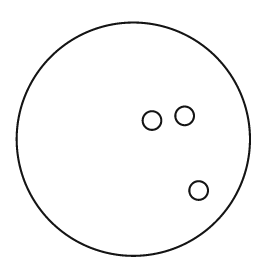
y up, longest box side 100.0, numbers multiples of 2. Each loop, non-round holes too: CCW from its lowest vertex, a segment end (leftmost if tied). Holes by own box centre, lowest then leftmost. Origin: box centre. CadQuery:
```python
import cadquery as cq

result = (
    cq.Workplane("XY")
    .moveTo(0.0, 0.0)
    .circle(50.0)
    .moveTo(28.0, -22.0)
    .circle(4.0)
    .moveTo(8.0, 8.0)
    .circle(4.0)
    .moveTo(22.0, 10.0)
    .circle(4.0)
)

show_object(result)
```